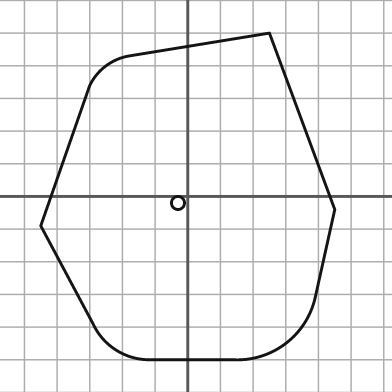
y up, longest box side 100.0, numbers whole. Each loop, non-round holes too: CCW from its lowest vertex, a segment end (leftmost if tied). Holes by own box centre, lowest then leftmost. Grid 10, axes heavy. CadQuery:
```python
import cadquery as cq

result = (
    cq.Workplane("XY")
    .moveTo(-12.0, -50.0)
    .lineTo(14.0, -50.0)
    .threePointArc((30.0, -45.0), (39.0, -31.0))
    .lineTo(45.0, -4.0)
    .lineTo(25.0, 50.0)
    .lineTo(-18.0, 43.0)
    .threePointArc((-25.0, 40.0), (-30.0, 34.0))
    .lineTo(-45.0, -9.0)
    .lineTo(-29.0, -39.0)
    .threePointArc((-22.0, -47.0), (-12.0, -50.0))
    .close()
    .moveTo(-3.0, -2.0)
    .circle(2.0)
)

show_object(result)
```